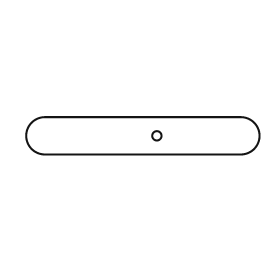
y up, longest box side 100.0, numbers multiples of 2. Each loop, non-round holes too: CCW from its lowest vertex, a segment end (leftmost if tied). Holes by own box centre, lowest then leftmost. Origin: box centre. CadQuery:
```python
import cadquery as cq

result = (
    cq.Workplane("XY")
    .moveTo(-42.0, -8.0)
    .lineTo(42.0, -8.0)
    .threePointArc((50.0, 0.0), (42.0, 8.0))
    .lineTo(-42.0, 8.0)
    .threePointArc((-50.0, 0.0), (-42.0, -8.0))
    .close()
    .moveTo(6.0, 0.0)
    .circle(2.0)
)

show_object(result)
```